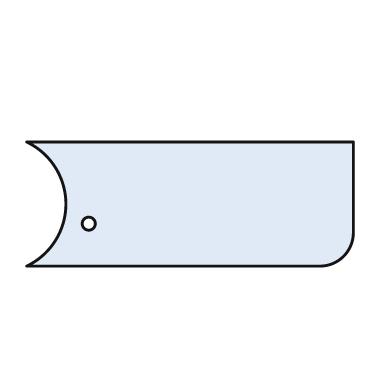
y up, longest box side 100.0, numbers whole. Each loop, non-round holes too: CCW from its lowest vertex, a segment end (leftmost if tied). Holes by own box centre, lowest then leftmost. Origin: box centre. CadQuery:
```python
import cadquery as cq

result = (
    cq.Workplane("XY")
    .moveTo(-50.0, -19.0)
    .lineTo(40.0, -19.0)
    .threePointArc((47.0, -16.0), (50.0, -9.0))
    .lineTo(50.0, 19.0)
    .lineTo(-50.0, 19.0)
    .threePointArc((-38.0, 0.0), (-50.0, -19.0))
    .close()
    .moveTo(-31.0, -6.0)
    .circle(2.0)
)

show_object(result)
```